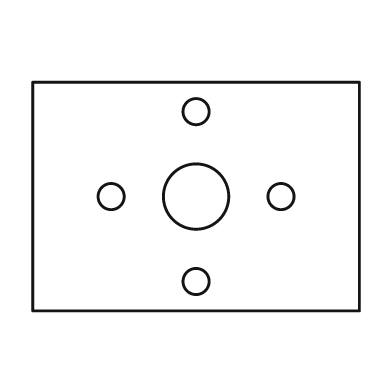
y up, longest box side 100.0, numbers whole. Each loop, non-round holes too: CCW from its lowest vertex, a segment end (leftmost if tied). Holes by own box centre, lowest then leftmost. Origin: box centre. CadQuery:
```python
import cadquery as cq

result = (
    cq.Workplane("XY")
    .moveTo(-50.0, -35.0)
    .lineTo(50.0, -35.0)
    .lineTo(50.0, 35.0)
    .lineTo(-50.0, 35.0)
    .close()
    .moveTo(0.0, -26.0)
    .circle(4.0)
    .moveTo(-26.0, 0.0)
    .circle(4.0)
    .moveTo(0.0, 0.0)
    .circle(10.0)
    .moveTo(26.0, 0.0)
    .circle(4.0)
    .moveTo(0.0, 26.0)
    .circle(4.0)
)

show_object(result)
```